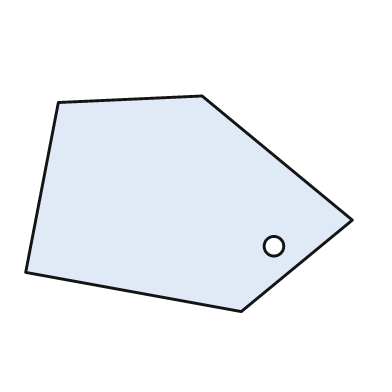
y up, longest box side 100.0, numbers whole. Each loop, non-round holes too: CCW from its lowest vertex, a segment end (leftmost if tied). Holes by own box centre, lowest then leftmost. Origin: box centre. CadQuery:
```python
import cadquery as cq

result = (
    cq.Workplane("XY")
    .moveTo(16.0, -33.0)
    .lineTo(50.0, -5.0)
    .lineTo(4.0, 33.0)
    .lineTo(-40.0, 31.0)
    .lineTo(-50.0, -21.0)
    .close()
    .moveTo(26.0, -13.0)
    .circle(3.0)
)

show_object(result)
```